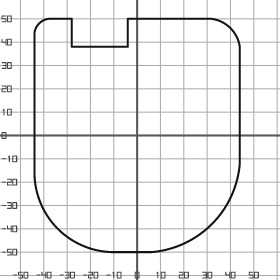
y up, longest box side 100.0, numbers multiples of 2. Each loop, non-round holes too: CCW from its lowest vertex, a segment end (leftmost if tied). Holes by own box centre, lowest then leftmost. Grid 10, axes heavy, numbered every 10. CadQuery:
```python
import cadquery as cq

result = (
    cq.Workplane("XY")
    .moveTo(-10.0, -50.0)
    .lineTo(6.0, -50.0)
    .threePointArc((32.0, -38.0), (44.0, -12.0))
    .lineTo(44.0, 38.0)
    .threePointArc((40.0, 46.0), (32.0, 50.0))
    .lineTo(-4.0, 50.0)
    .lineTo(-4.0, 38.0)
    .lineTo(-28.0, 38.0)
    .lineTo(-28.0, 50.0)
    .lineTo(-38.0, 50.0)
    .threePointArc((-42.0, 48.0), (-44.0, 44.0))
    .lineTo(-44.0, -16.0)
    .threePointArc((-34.0, -40.0), (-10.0, -50.0))
    .close()
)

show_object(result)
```